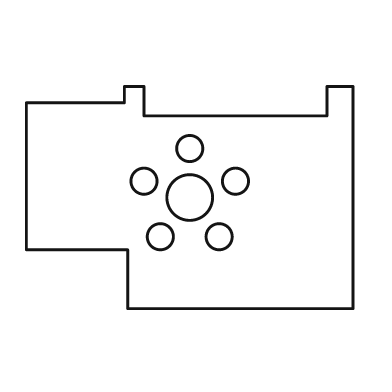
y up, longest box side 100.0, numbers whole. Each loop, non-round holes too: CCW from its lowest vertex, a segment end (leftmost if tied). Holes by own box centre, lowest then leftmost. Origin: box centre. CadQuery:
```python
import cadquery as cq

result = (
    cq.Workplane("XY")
    .moveTo(-19.0, -34.0)
    .lineTo(50.0, -34.0)
    .lineTo(50.0, 34.0)
    .lineTo(42.0, 34.0)
    .lineTo(42.0, 25.0)
    .lineTo(-14.0, 25.0)
    .lineTo(-14.0, 34.0)
    .lineTo(-20.0, 34.0)
    .lineTo(-20.0, 29.0)
    .lineTo(-50.0, 29.0)
    .lineTo(-50.0, -16.0)
    .lineTo(-19.0, -16.0)
    .close()
    .moveTo(-9.0, -12.0)
    .circle(4.0)
    .moveTo(9.0, -12.0)
    .circle(4.0)
    .moveTo(0.0, 0.0)
    .circle(7.0)
    .moveTo(-14.0, 5.0)
    .circle(4.0)
    .moveTo(14.0, 5.0)
    .circle(4.0)
    .moveTo(0.0, 15.0)
    .circle(4.0)
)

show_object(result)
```